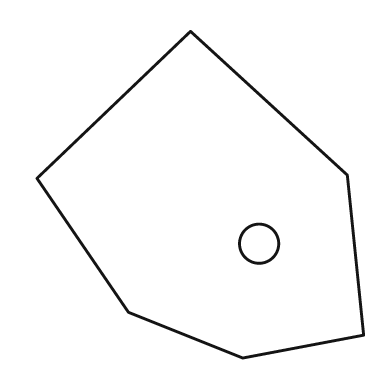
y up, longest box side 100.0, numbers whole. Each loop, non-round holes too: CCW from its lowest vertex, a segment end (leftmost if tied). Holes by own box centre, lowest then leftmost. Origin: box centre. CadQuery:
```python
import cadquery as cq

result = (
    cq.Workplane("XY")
    .moveTo(13.0, -50.0)
    .lineTo(50.0, -43.0)
    .lineTo(45.0, 6.0)
    .lineTo(-3.0, 50.0)
    .lineTo(-50.0, 5.0)
    .lineTo(-22.0, -36.0)
    .close()
    .moveTo(18.0, -15.0)
    .circle(6.0)
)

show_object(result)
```